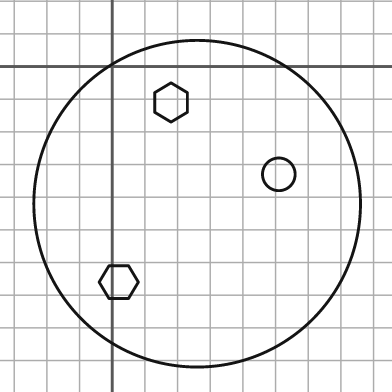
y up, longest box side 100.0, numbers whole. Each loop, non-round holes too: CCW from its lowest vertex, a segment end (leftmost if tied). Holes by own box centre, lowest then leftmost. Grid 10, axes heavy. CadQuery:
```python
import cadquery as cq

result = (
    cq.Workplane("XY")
    .moveTo(26.0, -42.0)
    .circle(50.0)
    .moveTo(-1.0, -71.0)
    .lineTo(5.0, -71.0)
    .lineTo(8.0, -66.0)
    .lineTo(5.0, -61.0)
    .lineTo(-1.0, -61.0)
    .lineTo(-4.0, -66.0)
    .close()
    .moveTo(51.0, -33.0)
    .circle(5.0)
    .moveTo(18.0, -17.0)
    .lineTo(23.0, -14.0)
    .lineTo(23.0, -8.0)
    .lineTo(18.0, -5.0)
    .lineTo(13.0, -8.0)
    .lineTo(13.0, -14.0)
    .close()
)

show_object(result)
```